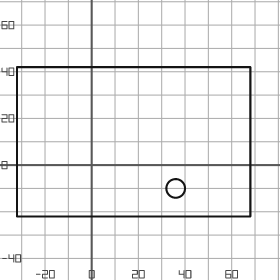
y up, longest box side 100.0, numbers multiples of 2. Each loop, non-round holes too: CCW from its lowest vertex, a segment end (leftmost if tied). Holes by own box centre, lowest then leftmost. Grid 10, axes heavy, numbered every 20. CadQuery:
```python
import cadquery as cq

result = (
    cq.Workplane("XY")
    .moveTo(-32.0, -22.0)
    .lineTo(68.0, -22.0)
    .lineTo(68.0, 42.0)
    .lineTo(-32.0, 42.0)
    .close()
    .moveTo(36.0, -10.0)
    .circle(4.0)
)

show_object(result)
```